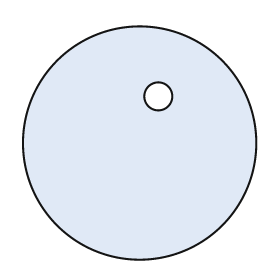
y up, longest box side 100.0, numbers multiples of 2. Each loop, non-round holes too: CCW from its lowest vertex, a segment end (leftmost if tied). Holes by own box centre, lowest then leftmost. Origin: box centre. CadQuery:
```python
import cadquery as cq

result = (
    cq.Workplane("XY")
    .moveTo(0.0, 0.0)
    .circle(50.0)
    .moveTo(8.0, 20.0)
    .circle(6.0)
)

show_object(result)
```